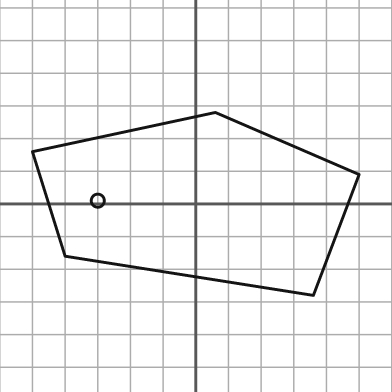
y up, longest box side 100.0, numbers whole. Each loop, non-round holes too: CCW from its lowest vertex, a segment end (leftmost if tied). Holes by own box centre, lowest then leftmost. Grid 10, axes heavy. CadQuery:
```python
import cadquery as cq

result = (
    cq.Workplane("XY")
    .moveTo(36.0, -28.0)
    .lineTo(50.0, 9.0)
    .lineTo(6.0, 28.0)
    .lineTo(-50.0, 16.0)
    .lineTo(-40.0, -16.0)
    .close()
    .moveTo(-30.0, 1.0)
    .circle(2.0)
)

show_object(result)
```